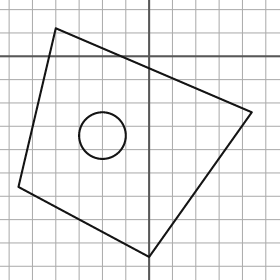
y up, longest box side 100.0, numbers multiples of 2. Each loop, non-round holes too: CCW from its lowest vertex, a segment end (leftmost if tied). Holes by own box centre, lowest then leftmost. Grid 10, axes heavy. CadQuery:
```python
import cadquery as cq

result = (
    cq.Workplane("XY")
    .moveTo(0.0, -86.0)
    .lineTo(44.0, -24.0)
    .lineTo(-40.0, 12.0)
    .lineTo(-56.0, -56.0)
    .close()
    .moveTo(-20.0, -34.0)
    .circle(10.0)
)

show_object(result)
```